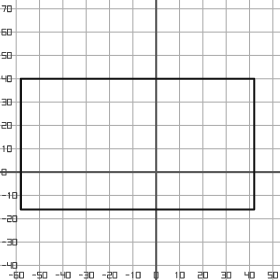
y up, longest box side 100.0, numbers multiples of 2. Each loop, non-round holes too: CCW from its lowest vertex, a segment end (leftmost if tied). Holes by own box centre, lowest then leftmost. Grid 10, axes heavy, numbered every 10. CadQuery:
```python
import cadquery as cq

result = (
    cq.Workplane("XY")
    .moveTo(-58.0, -16.0)
    .lineTo(42.0, -16.0)
    .lineTo(42.0, 40.0)
    .lineTo(-58.0, 40.0)
    .close()
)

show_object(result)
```